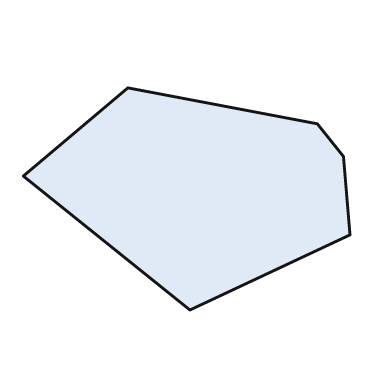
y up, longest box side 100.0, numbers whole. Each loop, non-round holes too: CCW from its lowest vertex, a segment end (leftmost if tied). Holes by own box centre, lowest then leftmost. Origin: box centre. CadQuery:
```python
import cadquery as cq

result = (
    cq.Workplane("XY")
    .moveTo(1.0, -34.0)
    .lineTo(50.0, -11.0)
    .lineTo(48.0, 13.0)
    .lineTo(40.0, 23.0)
    .lineTo(-18.0, 34.0)
    .lineTo(-50.0, 7.0)
    .close()
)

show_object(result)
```